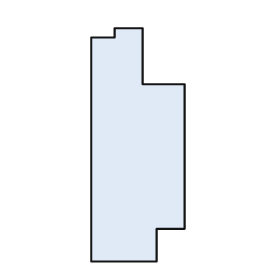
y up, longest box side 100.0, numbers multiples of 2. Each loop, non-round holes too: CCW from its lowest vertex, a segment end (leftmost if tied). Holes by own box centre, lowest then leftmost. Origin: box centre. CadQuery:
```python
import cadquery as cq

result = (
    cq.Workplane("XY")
    .moveTo(-20.0, -50.0)
    .lineTo(8.0, -50.0)
    .lineTo(8.0, -36.0)
    .lineTo(20.0, -36.0)
    .lineTo(20.0, 26.0)
    .lineTo(2.0, 26.0)
    .lineTo(2.0, 50.0)
    .lineTo(-10.0, 50.0)
    .lineTo(-10.0, 46.0)
    .lineTo(-20.0, 46.0)
    .close()
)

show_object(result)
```